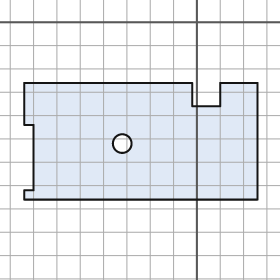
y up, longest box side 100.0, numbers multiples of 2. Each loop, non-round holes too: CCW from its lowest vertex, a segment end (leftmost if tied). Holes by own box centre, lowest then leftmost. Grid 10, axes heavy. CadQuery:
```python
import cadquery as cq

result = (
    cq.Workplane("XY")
    .moveTo(-74.0, -76.0)
    .lineTo(26.0, -76.0)
    .lineTo(26.0, -26.0)
    .lineTo(10.0, -26.0)
    .lineTo(10.0, -36.0)
    .lineTo(-2.0, -36.0)
    .lineTo(-2.0, -26.0)
    .lineTo(-74.0, -26.0)
    .lineTo(-74.0, -44.0)
    .lineTo(-70.0, -44.0)
    .lineTo(-70.0, -72.0)
    .lineTo(-74.0, -72.0)
    .close()
    .moveTo(-32.0, -52.0)
    .circle(4.0)
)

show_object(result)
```